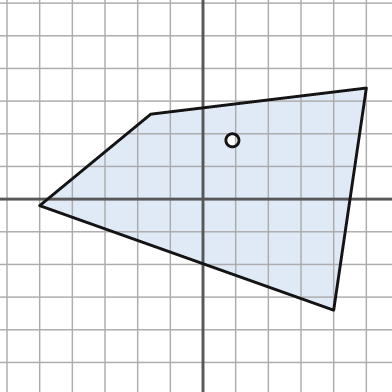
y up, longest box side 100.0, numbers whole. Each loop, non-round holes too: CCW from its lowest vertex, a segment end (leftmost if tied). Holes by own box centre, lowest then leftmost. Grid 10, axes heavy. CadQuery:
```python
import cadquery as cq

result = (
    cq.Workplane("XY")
    .moveTo(40.0, -34.0)
    .lineTo(50.0, 34.0)
    .lineTo(-16.0, 26.0)
    .lineTo(-50.0, -2.0)
    .close()
    .moveTo(9.0, 18.0)
    .circle(2.0)
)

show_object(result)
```